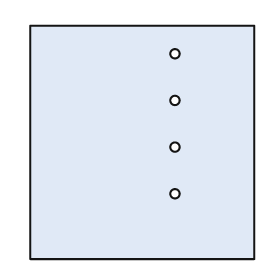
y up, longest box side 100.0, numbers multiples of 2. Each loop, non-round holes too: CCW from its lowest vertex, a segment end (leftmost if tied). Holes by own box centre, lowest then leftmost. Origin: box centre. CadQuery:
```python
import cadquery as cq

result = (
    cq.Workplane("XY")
    .moveTo(-48.0, -50.0)
    .lineTo(48.0, -50.0)
    .lineTo(48.0, 50.0)
    .lineTo(-48.0, 50.0)
    .close()
    .moveTo(14.0, -22.0)
    .circle(2.0)
    .moveTo(14.0, -2.0)
    .circle(2.0)
    .moveTo(14.0, 18.0)
    .circle(2.0)
    .moveTo(14.0, 38.0)
    .circle(2.0)
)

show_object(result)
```